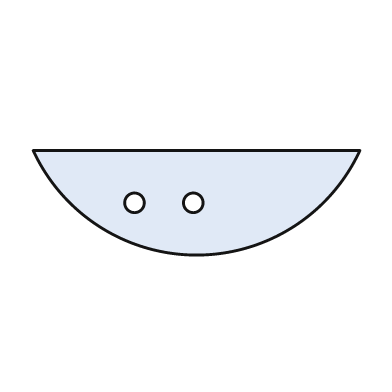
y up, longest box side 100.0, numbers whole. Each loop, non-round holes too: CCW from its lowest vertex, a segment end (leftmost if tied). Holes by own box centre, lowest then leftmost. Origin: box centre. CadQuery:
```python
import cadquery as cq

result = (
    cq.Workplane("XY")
    .moveTo(-50.0, 16.0)
    .threePointArc((0.0, -16.0), (50.0, 16.0))
    .close()
    .moveTo(-19.0, 0.0)
    .circle(3.0)
    .moveTo(-1.0, 0.0)
    .circle(3.0)
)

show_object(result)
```